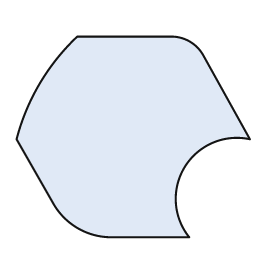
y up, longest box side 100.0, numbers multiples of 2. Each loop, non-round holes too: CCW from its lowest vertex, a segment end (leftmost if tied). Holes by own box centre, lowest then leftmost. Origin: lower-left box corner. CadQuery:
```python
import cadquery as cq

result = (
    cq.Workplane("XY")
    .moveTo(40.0, 0.0)
    .lineTo(74.0, 0.0)
    .threePointArc((72.0, 30.0), (100.0, 42.0))
    .lineTo(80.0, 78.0)
    .threePointArc((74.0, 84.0), (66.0, 86.0))
    .lineTo(26.0, 86.0)
    .threePointArc((10.0, 66.0), (0.0, 42.0))
    .lineTo(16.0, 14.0)
    .threePointArc((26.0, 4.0), (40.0, 0.0))
    .close()
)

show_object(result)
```